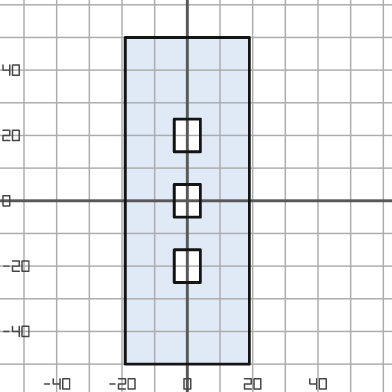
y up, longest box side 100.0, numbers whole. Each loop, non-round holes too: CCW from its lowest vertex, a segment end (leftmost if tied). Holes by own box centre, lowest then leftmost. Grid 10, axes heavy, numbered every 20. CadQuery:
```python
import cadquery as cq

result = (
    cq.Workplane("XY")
    .moveTo(-19.0, -50.0)
    .lineTo(19.0, -50.0)
    .lineTo(19.0, 50.0)
    .lineTo(-19.0, 50.0)
    .close()
    .moveTo(-4.0, -25.0)
    .lineTo(4.0, -25.0)
    .lineTo(4.0, -15.0)
    .lineTo(-4.0, -15.0)
    .close()
    .moveTo(-4.0, -5.0)
    .lineTo(4.0, -5.0)
    .lineTo(4.0, 5.0)
    .lineTo(-4.0, 5.0)
    .close()
    .moveTo(-4.0, 15.0)
    .lineTo(4.0, 15.0)
    .lineTo(4.0, 25.0)
    .lineTo(-4.0, 25.0)
    .close()
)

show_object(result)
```